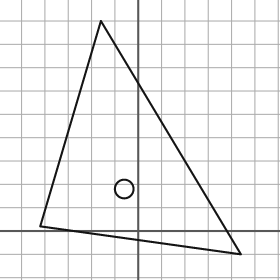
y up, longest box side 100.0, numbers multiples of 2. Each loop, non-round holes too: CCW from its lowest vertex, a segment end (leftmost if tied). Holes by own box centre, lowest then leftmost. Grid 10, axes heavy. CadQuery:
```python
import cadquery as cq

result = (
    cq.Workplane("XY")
    .moveTo(44.0, -10.0)
    .lineTo(-16.0, 90.0)
    .lineTo(-42.0, 2.0)
    .close()
    .moveTo(-6.0, 18.0)
    .circle(4.0)
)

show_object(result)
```